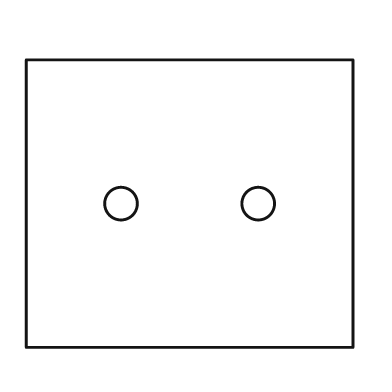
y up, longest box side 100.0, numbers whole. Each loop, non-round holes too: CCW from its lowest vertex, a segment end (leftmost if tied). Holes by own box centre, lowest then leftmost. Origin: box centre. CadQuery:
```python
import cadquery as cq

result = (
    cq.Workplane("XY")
    .moveTo(-50.0, -44.0)
    .lineTo(50.0, -44.0)
    .lineTo(50.0, 44.0)
    .lineTo(-50.0, 44.0)
    .close()
    .moveTo(-21.0, 0.0)
    .circle(5.0)
    .moveTo(21.0, 0.0)
    .circle(5.0)
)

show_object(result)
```